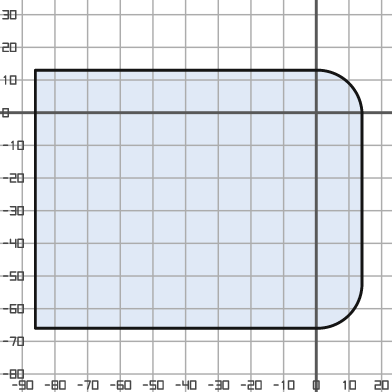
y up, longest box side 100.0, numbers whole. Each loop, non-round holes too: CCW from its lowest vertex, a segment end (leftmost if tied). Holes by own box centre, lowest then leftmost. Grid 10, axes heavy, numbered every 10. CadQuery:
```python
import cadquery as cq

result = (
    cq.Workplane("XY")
    .moveTo(-86.0, -66.0)
    .lineTo(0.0, -66.0)
    .threePointArc((10.0, -62.0), (14.0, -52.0))
    .lineTo(14.0, 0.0)
    .threePointArc((10.0, 9.0), (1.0, 13.0))
    .lineTo(-86.0, 13.0)
    .close()
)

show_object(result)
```